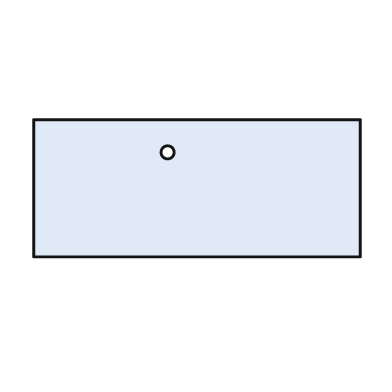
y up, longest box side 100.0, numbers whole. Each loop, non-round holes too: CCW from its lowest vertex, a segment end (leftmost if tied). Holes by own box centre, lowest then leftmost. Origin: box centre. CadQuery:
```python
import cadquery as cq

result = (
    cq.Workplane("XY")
    .moveTo(-50.0, -21.0)
    .lineTo(50.0, -21.0)
    .lineTo(50.0, 21.0)
    .lineTo(-50.0, 21.0)
    .close()
    .moveTo(-9.0, 11.0)
    .circle(2.0)
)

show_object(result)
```